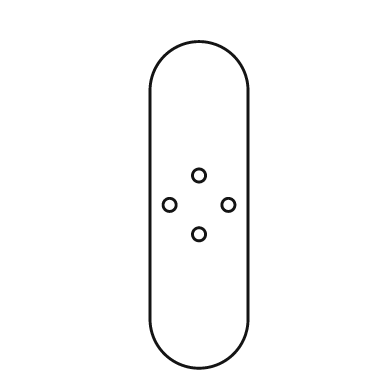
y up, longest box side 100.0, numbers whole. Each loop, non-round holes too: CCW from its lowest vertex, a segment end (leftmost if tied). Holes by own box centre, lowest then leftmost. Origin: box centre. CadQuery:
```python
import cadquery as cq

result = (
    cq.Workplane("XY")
    .moveTo(-15.0, -35.0)
    .threePointArc((0.0, -50.0), (15.0, -35.0))
    .lineTo(15.0, 35.0)
    .threePointArc((0.0, 50.0), (-15.0, 35.0))
    .close()
    .moveTo(0.0, -9.0)
    .circle(2.0)
    .moveTo(-9.0, 0.0)
    .circle(2.0)
    .moveTo(9.0, 0.0)
    .circle(2.0)
    .moveTo(0.0, 9.0)
    .circle(2.0)
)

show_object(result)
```